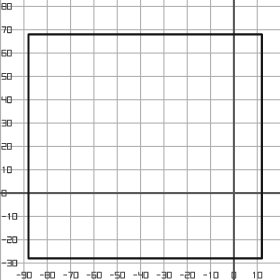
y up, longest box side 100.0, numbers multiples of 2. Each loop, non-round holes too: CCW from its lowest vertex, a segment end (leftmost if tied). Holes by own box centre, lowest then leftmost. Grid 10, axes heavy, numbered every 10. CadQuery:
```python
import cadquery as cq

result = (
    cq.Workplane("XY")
    .moveTo(-88.0, -28.0)
    .lineTo(12.0, -28.0)
    .lineTo(12.0, 68.0)
    .lineTo(-88.0, 68.0)
    .close()
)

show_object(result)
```